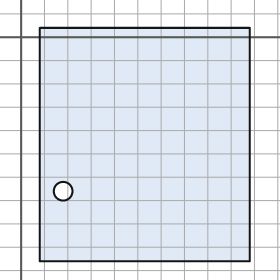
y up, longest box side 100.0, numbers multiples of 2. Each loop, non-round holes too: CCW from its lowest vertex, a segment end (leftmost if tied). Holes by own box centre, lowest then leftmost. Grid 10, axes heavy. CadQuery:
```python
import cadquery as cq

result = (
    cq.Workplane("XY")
    .moveTo(8.0, -96.0)
    .lineTo(98.0, -96.0)
    .lineTo(98.0, 4.0)
    .lineTo(8.0, 4.0)
    .close()
    .moveTo(18.0, -66.0)
    .circle(4.0)
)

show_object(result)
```